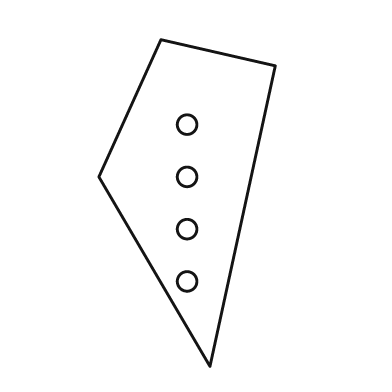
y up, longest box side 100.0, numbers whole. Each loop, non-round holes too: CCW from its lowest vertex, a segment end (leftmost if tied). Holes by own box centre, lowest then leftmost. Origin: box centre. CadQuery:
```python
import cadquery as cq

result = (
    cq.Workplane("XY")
    .moveTo(7.0, -50.0)
    .lineTo(27.0, 42.0)
    .lineTo(-8.0, 50.0)
    .lineTo(-27.0, 8.0)
    .close()
    .moveTo(0.0, -24.0)
    .circle(3.0)
    .moveTo(0.0, -8.0)
    .circle(3.0)
    .moveTo(0.0, 8.0)
    .circle(3.0)
    .moveTo(0.0, 24.0)
    .circle(3.0)
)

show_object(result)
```